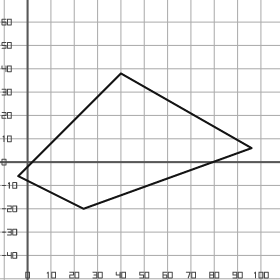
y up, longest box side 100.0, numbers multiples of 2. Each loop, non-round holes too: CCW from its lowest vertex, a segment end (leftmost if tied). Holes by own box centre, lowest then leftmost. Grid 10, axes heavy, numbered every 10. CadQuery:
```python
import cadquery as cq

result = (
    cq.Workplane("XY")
    .moveTo(24.0, -20.0)
    .lineTo(96.0, 6.0)
    .lineTo(40.0, 38.0)
    .lineTo(-4.0, -6.0)
    .close()
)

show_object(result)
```